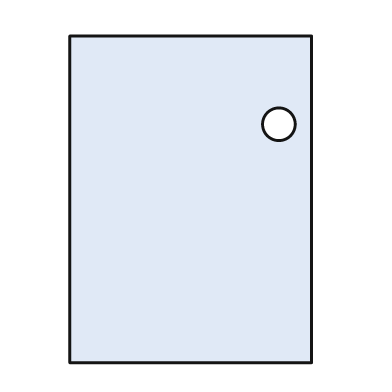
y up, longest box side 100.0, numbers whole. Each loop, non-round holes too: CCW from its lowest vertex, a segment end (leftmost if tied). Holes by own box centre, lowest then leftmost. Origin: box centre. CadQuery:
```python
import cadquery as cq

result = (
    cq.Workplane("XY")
    .moveTo(-37.0, -50.0)
    .lineTo(37.0, -50.0)
    .lineTo(37.0, 50.0)
    .lineTo(-37.0, 50.0)
    .close()
    .moveTo(27.0, 23.0)
    .circle(5.0)
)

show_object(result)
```